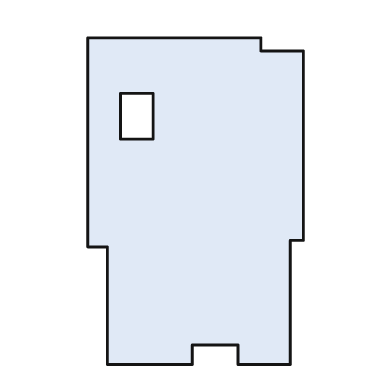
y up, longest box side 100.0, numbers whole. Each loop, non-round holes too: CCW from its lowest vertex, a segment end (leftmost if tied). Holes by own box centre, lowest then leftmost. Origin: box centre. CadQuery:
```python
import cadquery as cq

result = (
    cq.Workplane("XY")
    .moveTo(-27.0, -50.0)
    .lineTo(-1.0, -50.0)
    .lineTo(-1.0, -44.0)
    .lineTo(13.0, -44.0)
    .lineTo(13.0, -50.0)
    .lineTo(29.0, -50.0)
    .lineTo(29.0, -12.0)
    .lineTo(33.0, -12.0)
    .lineTo(33.0, 46.0)
    .lineTo(20.0, 46.0)
    .lineTo(20.0, 50.0)
    .lineTo(-33.0, 50.0)
    .lineTo(-33.0, -14.0)
    .lineTo(-27.0, -14.0)
    .close()
    .moveTo(-23.0, 19.0)
    .lineTo(-13.0, 19.0)
    .lineTo(-13.0, 33.0)
    .lineTo(-23.0, 33.0)
    .close()
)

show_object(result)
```